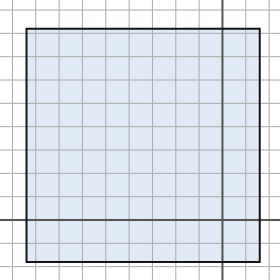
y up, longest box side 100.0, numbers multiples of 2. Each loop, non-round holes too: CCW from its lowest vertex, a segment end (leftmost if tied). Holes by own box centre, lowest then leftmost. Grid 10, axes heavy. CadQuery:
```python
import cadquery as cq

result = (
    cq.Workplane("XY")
    .moveTo(-84.0, -18.0)
    .lineTo(16.0, -18.0)
    .lineTo(16.0, 82.0)
    .lineTo(-84.0, 82.0)
    .close()
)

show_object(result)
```